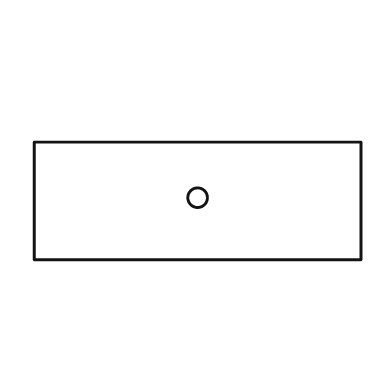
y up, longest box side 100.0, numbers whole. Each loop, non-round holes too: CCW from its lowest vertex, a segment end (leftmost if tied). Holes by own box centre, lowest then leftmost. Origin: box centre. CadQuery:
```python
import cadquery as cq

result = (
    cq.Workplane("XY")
    .moveTo(-50.0, -18.0)
    .lineTo(50.0, -18.0)
    .lineTo(50.0, 18.0)
    .lineTo(-50.0, 18.0)
    .close()
    .moveTo(0.0, 1.0)
    .circle(3.0)
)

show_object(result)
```